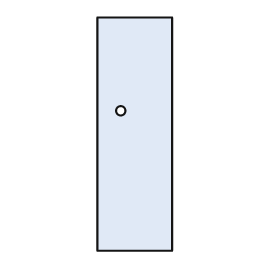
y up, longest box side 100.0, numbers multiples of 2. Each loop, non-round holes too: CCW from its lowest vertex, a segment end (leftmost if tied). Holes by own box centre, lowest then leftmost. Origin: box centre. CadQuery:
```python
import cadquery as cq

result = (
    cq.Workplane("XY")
    .moveTo(-16.0, -50.0)
    .lineTo(16.0, -50.0)
    .lineTo(16.0, 50.0)
    .lineTo(-16.0, 50.0)
    .close()
    .moveTo(-6.0, 10.0)
    .circle(2.0)
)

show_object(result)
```